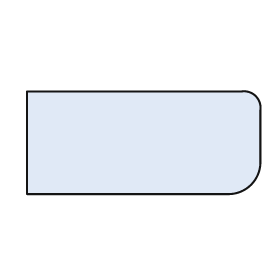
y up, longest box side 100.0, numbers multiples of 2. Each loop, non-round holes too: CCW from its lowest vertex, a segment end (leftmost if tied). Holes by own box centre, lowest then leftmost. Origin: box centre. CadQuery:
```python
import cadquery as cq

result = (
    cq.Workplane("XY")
    .moveTo(-50.0, -22.0)
    .lineTo(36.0, -22.0)
    .threePointArc((46.0, -18.0), (50.0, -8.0))
    .lineTo(50.0, 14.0)
    .threePointArc((48.0, 20.0), (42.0, 22.0))
    .lineTo(-50.0, 22.0)
    .close()
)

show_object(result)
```